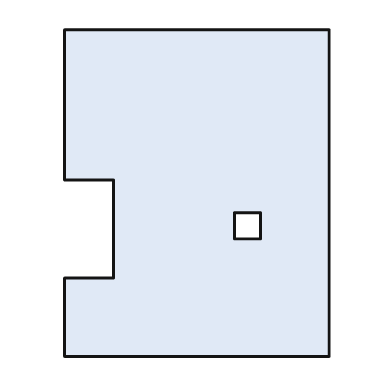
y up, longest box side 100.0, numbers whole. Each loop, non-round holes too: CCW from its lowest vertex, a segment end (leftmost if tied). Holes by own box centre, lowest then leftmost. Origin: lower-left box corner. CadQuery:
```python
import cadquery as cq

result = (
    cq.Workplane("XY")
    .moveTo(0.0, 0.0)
    .lineTo(81.0, 0.0)
    .lineTo(81.0, 100.0)
    .lineTo(0.0, 100.0)
    .lineTo(0.0, 54.0)
    .lineTo(15.0, 54.0)
    .lineTo(15.0, 24.0)
    .lineTo(0.0, 24.0)
    .close()
    .moveTo(52.0, 36.0)
    .lineTo(60.0, 36.0)
    .lineTo(60.0, 44.0)
    .lineTo(52.0, 44.0)
    .close()
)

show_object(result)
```